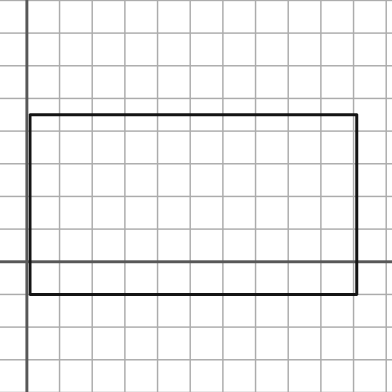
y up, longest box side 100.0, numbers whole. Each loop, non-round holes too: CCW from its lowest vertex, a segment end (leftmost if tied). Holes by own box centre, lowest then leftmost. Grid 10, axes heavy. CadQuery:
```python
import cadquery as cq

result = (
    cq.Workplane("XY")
    .moveTo(1.0, -10.0)
    .lineTo(101.0, -10.0)
    .lineTo(101.0, 45.0)
    .lineTo(1.0, 45.0)
    .close()
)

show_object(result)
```